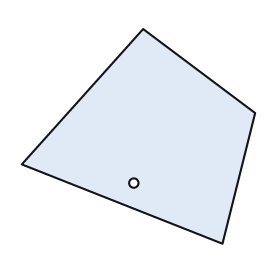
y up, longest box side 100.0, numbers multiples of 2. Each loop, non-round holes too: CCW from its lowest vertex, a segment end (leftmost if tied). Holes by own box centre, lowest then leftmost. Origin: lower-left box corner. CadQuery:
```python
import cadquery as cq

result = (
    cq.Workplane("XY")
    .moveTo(86.0, 0.0)
    .lineTo(100.0, 56.0)
    .lineTo(52.0, 92.0)
    .lineTo(0.0, 34.0)
    .close()
    .moveTo(48.0, 26.0)
    .circle(2.0)
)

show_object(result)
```